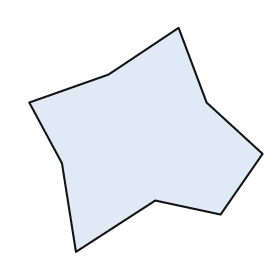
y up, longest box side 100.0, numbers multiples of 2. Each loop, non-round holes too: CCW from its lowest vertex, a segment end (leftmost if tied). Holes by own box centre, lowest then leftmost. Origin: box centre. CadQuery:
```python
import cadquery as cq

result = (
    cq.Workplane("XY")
    .moveTo(-30.0, -48.0)
    .lineTo(4.0, -26.0)
    .lineTo(32.0, -32.0)
    .lineTo(50.0, -6.0)
    .lineTo(26.0, 16.0)
    .lineTo(14.0, 48.0)
    .lineTo(-16.0, 28.0)
    .lineTo(-50.0, 16.0)
    .lineTo(-36.0, -10.0)
    .close()
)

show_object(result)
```